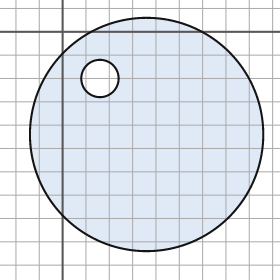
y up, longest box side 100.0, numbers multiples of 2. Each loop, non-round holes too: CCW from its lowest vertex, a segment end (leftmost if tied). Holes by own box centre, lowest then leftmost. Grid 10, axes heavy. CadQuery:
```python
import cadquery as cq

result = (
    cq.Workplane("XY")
    .moveTo(36.0, -44.0)
    .circle(50.0)
    .moveTo(16.0, -20.0)
    .circle(8.0)
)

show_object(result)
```